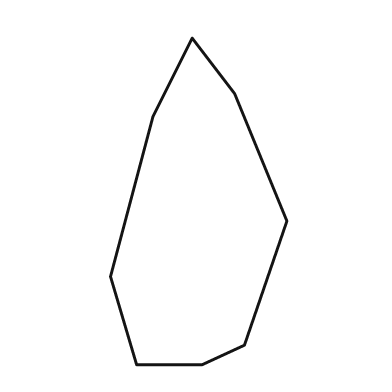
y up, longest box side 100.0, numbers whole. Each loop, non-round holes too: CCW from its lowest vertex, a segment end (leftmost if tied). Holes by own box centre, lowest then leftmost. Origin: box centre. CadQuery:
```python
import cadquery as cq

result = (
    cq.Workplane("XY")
    .moveTo(-19.0, -50.0)
    .lineTo(1.0, -50.0)
    .lineTo(14.0, -44.0)
    .lineTo(27.0, -6.0)
    .lineTo(11.0, 33.0)
    .lineTo(-2.0, 50.0)
    .lineTo(-14.0, 26.0)
    .lineTo(-27.0, -23.0)
    .close()
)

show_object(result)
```